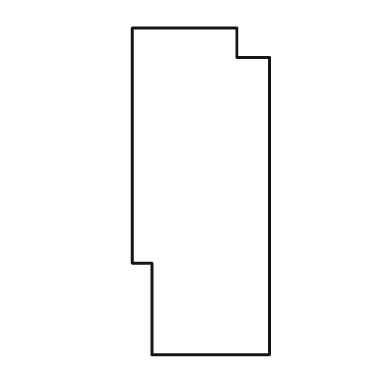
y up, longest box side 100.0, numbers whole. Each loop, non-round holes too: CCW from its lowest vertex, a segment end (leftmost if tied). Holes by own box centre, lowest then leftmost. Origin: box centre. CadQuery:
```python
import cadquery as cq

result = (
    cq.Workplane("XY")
    .moveTo(-15.0, -50.0)
    .lineTo(21.0, -50.0)
    .lineTo(21.0, 41.0)
    .lineTo(11.0, 41.0)
    .lineTo(11.0, 50.0)
    .lineTo(-21.0, 50.0)
    .lineTo(-21.0, -22.0)
    .lineTo(-15.0, -22.0)
    .close()
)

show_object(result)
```